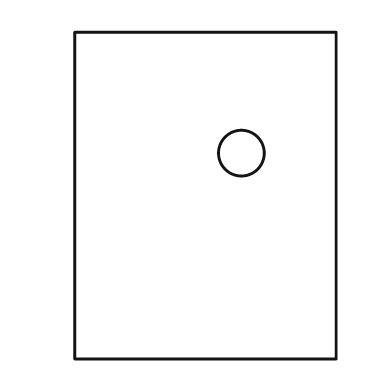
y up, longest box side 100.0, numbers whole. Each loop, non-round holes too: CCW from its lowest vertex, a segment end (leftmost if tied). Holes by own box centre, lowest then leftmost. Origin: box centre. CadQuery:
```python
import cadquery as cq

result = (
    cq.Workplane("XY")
    .moveTo(-40.0, -50.0)
    .lineTo(40.0, -50.0)
    .lineTo(40.0, 50.0)
    .lineTo(-40.0, 50.0)
    .close()
    .moveTo(11.0, 13.0)
    .circle(7.0)
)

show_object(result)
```